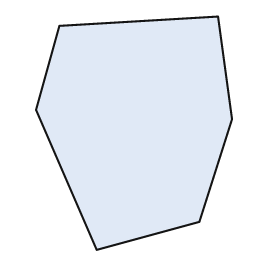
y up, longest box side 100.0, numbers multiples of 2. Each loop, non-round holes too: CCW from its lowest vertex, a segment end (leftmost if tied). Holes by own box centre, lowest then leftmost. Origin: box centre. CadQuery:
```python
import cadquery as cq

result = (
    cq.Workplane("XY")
    .moveTo(-16.0, -50.0)
    .lineTo(28.0, -38.0)
    .lineTo(42.0, 6.0)
    .lineTo(36.0, 50.0)
    .lineTo(-32.0, 46.0)
    .lineTo(-42.0, 10.0)
    .close()
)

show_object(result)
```